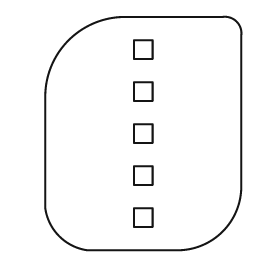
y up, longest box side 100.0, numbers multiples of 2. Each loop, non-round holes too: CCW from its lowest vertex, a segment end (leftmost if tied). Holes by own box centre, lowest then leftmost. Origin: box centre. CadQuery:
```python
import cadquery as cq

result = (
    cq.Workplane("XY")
    .moveTo(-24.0, -50.0)
    .lineTo(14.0, -50.0)
    .threePointArc((34.0, -42.0), (42.0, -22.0))
    .lineTo(42.0, 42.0)
    .threePointArc((40.0, 48.0), (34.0, 50.0))
    .lineTo(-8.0, 50.0)
    .threePointArc((-32.0, 40.0), (-42.0, 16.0))
    .lineTo(-42.0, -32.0)
    .threePointArc((-36.0, -44.0), (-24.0, -50.0))
    .close()
    .moveTo(-4.0, -40.0)
    .lineTo(4.0, -40.0)
    .lineTo(4.0, -32.0)
    .lineTo(-4.0, -32.0)
    .close()
    .moveTo(-4.0, -22.0)
    .lineTo(4.0, -22.0)
    .lineTo(4.0, -14.0)
    .lineTo(-4.0, -14.0)
    .close()
    .moveTo(-4.0, -4.0)
    .lineTo(4.0, -4.0)
    .lineTo(4.0, 4.0)
    .lineTo(-4.0, 4.0)
    .close()
    .moveTo(-4.0, 14.0)
    .lineTo(4.0, 14.0)
    .lineTo(4.0, 22.0)
    .lineTo(-4.0, 22.0)
    .close()
    .moveTo(-4.0, 32.0)
    .lineTo(4.0, 32.0)
    .lineTo(4.0, 40.0)
    .lineTo(-4.0, 40.0)
    .close()
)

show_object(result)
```